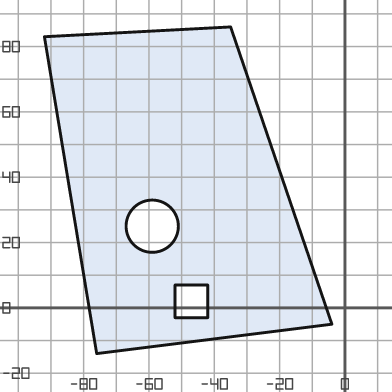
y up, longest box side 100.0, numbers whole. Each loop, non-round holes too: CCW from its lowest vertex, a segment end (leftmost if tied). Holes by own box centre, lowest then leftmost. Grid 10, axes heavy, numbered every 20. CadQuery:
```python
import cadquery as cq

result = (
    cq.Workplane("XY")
    .moveTo(-76.0, -14.0)
    .lineTo(-4.0, -5.0)
    .lineTo(-35.0, 86.0)
    .lineTo(-92.0, 83.0)
    .close()
    .moveTo(-52.0, -3.0)
    .lineTo(-42.0, -3.0)
    .lineTo(-42.0, 7.0)
    .lineTo(-52.0, 7.0)
    .close()
    .moveTo(-59.0, 25.0)
    .circle(8.0)
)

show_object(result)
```